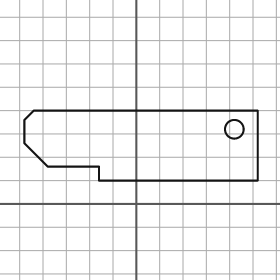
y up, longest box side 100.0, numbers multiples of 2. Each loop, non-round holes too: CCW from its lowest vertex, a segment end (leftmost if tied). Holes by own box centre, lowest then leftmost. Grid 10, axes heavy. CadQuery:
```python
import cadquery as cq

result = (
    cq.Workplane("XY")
    .moveTo(-16.0, 10.0)
    .lineTo(52.0, 10.0)
    .lineTo(52.0, 40.0)
    .lineTo(-44.0, 40.0)
    .lineTo(-48.0, 36.0)
    .lineTo(-48.0, 26.0)
    .lineTo(-38.0, 16.0)
    .lineTo(-16.0, 16.0)
    .close()
    .moveTo(42.0, 32.0)
    .circle(4.0)
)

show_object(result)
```